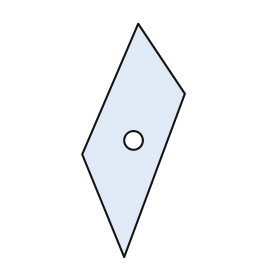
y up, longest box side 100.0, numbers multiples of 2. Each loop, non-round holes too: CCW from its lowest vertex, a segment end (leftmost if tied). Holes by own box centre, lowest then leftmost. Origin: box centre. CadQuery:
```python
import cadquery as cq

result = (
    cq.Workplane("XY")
    .moveTo(-4.0, -50.0)
    .lineTo(22.0, 20.0)
    .lineTo(2.0, 50.0)
    .lineTo(-22.0, -6.0)
    .close()
    .moveTo(0.0, 0.0)
    .circle(4.0)
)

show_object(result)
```